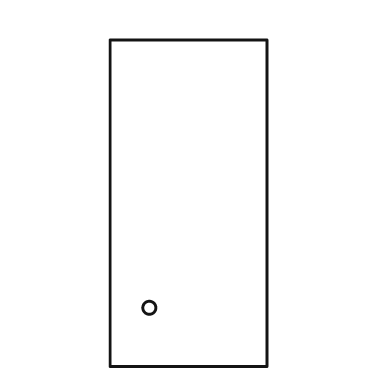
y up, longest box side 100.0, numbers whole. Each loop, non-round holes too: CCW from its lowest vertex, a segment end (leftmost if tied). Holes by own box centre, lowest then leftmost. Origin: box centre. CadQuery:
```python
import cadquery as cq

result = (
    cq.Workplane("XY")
    .moveTo(-24.0, -50.0)
    .lineTo(24.0, -50.0)
    .lineTo(24.0, 50.0)
    .lineTo(-24.0, 50.0)
    .close()
    .moveTo(-12.0, -32.0)
    .circle(2.0)
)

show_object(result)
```